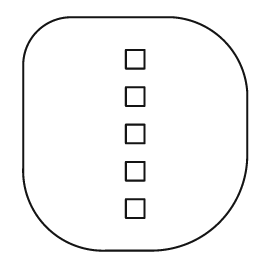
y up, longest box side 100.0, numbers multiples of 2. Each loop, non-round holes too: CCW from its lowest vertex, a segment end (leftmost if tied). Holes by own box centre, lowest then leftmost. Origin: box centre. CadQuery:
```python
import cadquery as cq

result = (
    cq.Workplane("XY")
    .moveTo(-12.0, -50.0)
    .lineTo(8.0, -50.0)
    .threePointArc((36.0, -38.0), (48.0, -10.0))
    .lineTo(48.0, 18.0)
    .threePointArc((38.0, 40.0), (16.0, 50.0))
    .lineTo(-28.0, 50.0)
    .threePointArc((-42.0, 44.0), (-48.0, 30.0))
    .lineTo(-48.0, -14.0)
    .threePointArc((-38.0, -40.0), (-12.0, -50.0))
    .close()
    .moveTo(-4.0, -36.0)
    .lineTo(4.0, -36.0)
    .lineTo(4.0, -28.0)
    .lineTo(-4.0, -28.0)
    .close()
    .moveTo(-4.0, -20.0)
    .lineTo(4.0, -20.0)
    .lineTo(4.0, -12.0)
    .lineTo(-4.0, -12.0)
    .close()
    .moveTo(-4.0, -4.0)
    .lineTo(4.0, -4.0)
    .lineTo(4.0, 4.0)
    .lineTo(-4.0, 4.0)
    .close()
    .moveTo(-4.0, 12.0)
    .lineTo(4.0, 12.0)
    .lineTo(4.0, 20.0)
    .lineTo(-4.0, 20.0)
    .close()
    .moveTo(-4.0, 28.0)
    .lineTo(4.0, 28.0)
    .lineTo(4.0, 36.0)
    .lineTo(-4.0, 36.0)
    .close()
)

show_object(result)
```